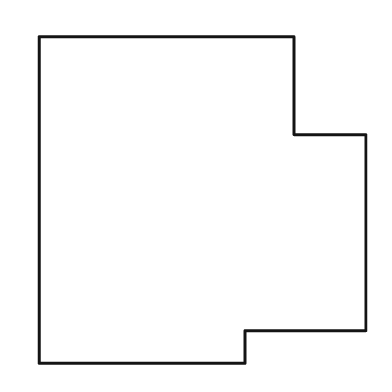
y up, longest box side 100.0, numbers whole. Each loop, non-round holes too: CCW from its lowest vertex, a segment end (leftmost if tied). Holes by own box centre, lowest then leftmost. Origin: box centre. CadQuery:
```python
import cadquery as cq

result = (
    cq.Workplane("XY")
    .moveTo(-50.0, -50.0)
    .lineTo(13.0, -50.0)
    .lineTo(13.0, -40.0)
    .lineTo(50.0, -40.0)
    .lineTo(50.0, 20.0)
    .lineTo(28.0, 20.0)
    .lineTo(28.0, 50.0)
    .lineTo(-50.0, 50.0)
    .close()
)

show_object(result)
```